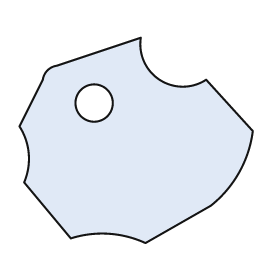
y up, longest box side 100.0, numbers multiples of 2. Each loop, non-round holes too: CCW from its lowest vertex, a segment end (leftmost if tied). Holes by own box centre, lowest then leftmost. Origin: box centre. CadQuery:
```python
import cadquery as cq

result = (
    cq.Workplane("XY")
    .moveTo(4.0, -44.0)
    .lineTo(32.0, -28.0)
    .threePointArc((44.0, -14.0), (50.0, 4.0))
    .lineTo(30.0, 26.0)
    .threePointArc((10.0, 26.0), (2.0, 44.0))
    .lineTo(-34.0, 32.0)
    .threePointArc((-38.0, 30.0), (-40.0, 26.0))
    .lineTo(-50.0, 6.0)
    .threePointArc((-46.0, -6.0), (-48.0, -18.0))
    .lineTo(-28.0, -42.0)
    .threePointArc((-12.0, -40.0), (4.0, -44.0))
    .close()
    .moveTo(-18.0, 16.0)
    .circle(8.0)
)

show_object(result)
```